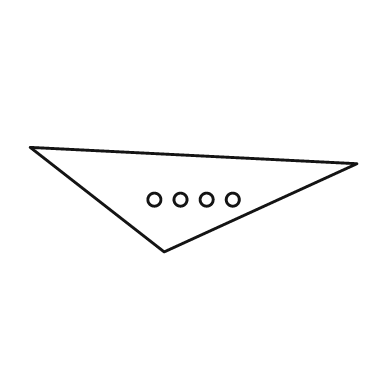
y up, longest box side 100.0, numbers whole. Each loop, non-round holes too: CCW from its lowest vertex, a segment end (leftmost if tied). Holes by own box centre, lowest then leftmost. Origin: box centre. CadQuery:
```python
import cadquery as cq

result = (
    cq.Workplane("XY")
    .moveTo(-9.0, -16.0)
    .lineTo(50.0, 11.0)
    .lineTo(-50.0, 16.0)
    .close()
    .moveTo(-12.0, 0.0)
    .circle(2.0)
    .moveTo(-4.0, 0.0)
    .circle(2.0)
    .moveTo(4.0, 0.0)
    .circle(2.0)
    .moveTo(12.0, 0.0)
    .circle(2.0)
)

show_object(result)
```